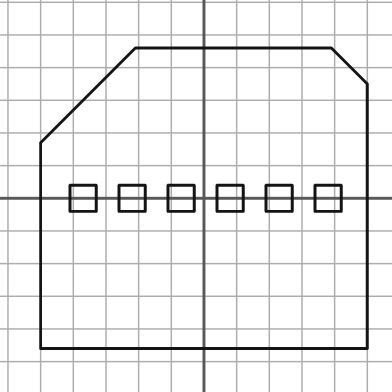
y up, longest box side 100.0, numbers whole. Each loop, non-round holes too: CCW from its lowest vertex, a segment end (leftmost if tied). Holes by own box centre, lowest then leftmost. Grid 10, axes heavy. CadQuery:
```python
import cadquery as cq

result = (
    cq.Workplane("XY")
    .moveTo(-50.0, -46.0)
    .lineTo(50.0, -46.0)
    .lineTo(50.0, 35.0)
    .lineTo(39.0, 46.0)
    .lineTo(-21.0, 46.0)
    .lineTo(-50.0, 17.0)
    .close()
    .moveTo(-41.0, -4.0)
    .lineTo(-33.0, -4.0)
    .lineTo(-33.0, 4.0)
    .lineTo(-41.0, 4.0)
    .close()
    .moveTo(-26.0, -4.0)
    .lineTo(-18.0, -4.0)
    .lineTo(-18.0, 4.0)
    .lineTo(-26.0, 4.0)
    .close()
    .moveTo(-11.0, -4.0)
    .lineTo(-3.0, -4.0)
    .lineTo(-3.0, 4.0)
    .lineTo(-11.0, 4.0)
    .close()
    .moveTo(4.0, -4.0)
    .lineTo(12.0, -4.0)
    .lineTo(12.0, 4.0)
    .lineTo(4.0, 4.0)
    .close()
    .moveTo(19.0, -4.0)
    .lineTo(27.0, -4.0)
    .lineTo(27.0, 4.0)
    .lineTo(19.0, 4.0)
    .close()
    .moveTo(34.0, -4.0)
    .lineTo(42.0, -4.0)
    .lineTo(42.0, 4.0)
    .lineTo(34.0, 4.0)
    .close()
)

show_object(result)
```